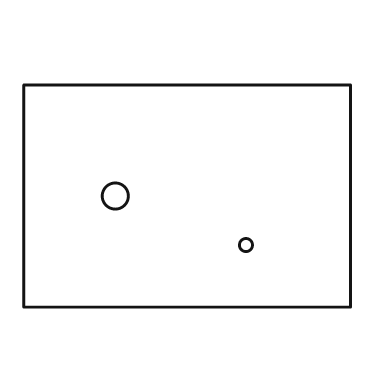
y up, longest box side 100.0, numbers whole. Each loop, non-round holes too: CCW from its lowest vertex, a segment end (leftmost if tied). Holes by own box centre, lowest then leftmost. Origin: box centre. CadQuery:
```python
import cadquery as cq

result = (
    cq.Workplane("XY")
    .moveTo(-50.0, -34.0)
    .lineTo(50.0, -34.0)
    .lineTo(50.0, 34.0)
    .lineTo(-50.0, 34.0)
    .close()
    .moveTo(18.0, -15.0)
    .circle(2.0)
    .moveTo(-22.0, 0.0)
    .circle(4.0)
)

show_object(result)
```